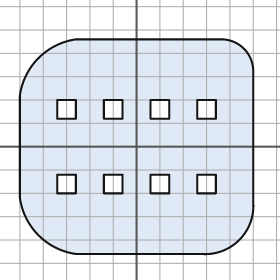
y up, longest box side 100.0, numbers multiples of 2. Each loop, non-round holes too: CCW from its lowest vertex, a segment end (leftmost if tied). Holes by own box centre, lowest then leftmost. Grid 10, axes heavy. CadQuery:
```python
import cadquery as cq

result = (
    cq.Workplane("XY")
    .moveTo(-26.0, -46.0)
    .lineTo(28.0, -46.0)
    .threePointArc((44.0, -40.0), (50.0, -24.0))
    .lineTo(50.0, 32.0)
    .threePointArc((46.0, 42.0), (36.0, 46.0))
    .lineTo(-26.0, 46.0)
    .threePointArc((-42.0, 38.0), (-50.0, 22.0))
    .lineTo(-50.0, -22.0)
    .threePointArc((-42.0, -38.0), (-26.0, -46.0))
    .close()
    .moveTo(-34.0, -20.0)
    .lineTo(-26.0, -20.0)
    .lineTo(-26.0, -12.0)
    .lineTo(-34.0, -12.0)
    .close()
    .moveTo(-14.0, -20.0)
    .lineTo(-6.0, -20.0)
    .lineTo(-6.0, -12.0)
    .lineTo(-14.0, -12.0)
    .close()
    .moveTo(6.0, -20.0)
    .lineTo(14.0, -20.0)
    .lineTo(14.0, -12.0)
    .lineTo(6.0, -12.0)
    .close()
    .moveTo(26.0, -20.0)
    .lineTo(34.0, -20.0)
    .lineTo(34.0, -12.0)
    .lineTo(26.0, -12.0)
    .close()
    .moveTo(-34.0, 12.0)
    .lineTo(-26.0, 12.0)
    .lineTo(-26.0, 20.0)
    .lineTo(-34.0, 20.0)
    .close()
    .moveTo(-14.0, 12.0)
    .lineTo(-6.0, 12.0)
    .lineTo(-6.0, 20.0)
    .lineTo(-14.0, 20.0)
    .close()
    .moveTo(6.0, 12.0)
    .lineTo(14.0, 12.0)
    .lineTo(14.0, 20.0)
    .lineTo(6.0, 20.0)
    .close()
    .moveTo(26.0, 12.0)
    .lineTo(34.0, 12.0)
    .lineTo(34.0, 20.0)
    .lineTo(26.0, 20.0)
    .close()
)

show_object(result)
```